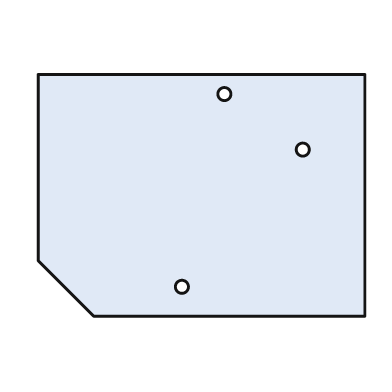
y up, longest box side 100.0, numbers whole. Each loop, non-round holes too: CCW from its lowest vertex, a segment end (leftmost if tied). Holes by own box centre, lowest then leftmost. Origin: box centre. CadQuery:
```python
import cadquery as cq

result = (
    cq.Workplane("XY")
    .moveTo(-33.0, -37.0)
    .lineTo(50.0, -37.0)
    .lineTo(50.0, 37.0)
    .lineTo(-50.0, 37.0)
    .lineTo(-50.0, -20.0)
    .close()
    .moveTo(-6.0, -28.0)
    .circle(2.0)
    .moveTo(31.0, 14.0)
    .circle(2.0)
    .moveTo(7.0, 31.0)
    .circle(2.0)
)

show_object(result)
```